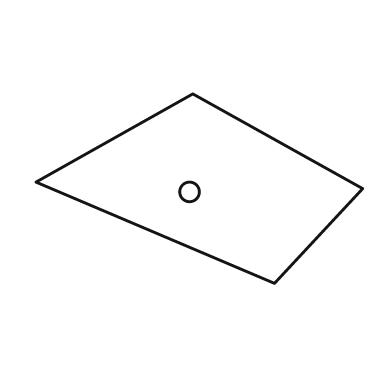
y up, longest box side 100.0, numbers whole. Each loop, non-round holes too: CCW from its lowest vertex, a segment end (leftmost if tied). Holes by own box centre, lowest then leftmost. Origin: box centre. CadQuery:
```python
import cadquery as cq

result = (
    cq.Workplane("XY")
    .moveTo(23.0, -29.0)
    .lineTo(50.0, 0.0)
    .lineTo(-2.0, 29.0)
    .lineTo(-50.0, 2.0)
    .close()
    .moveTo(-3.0, -1.0)
    .circle(3.0)
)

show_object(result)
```